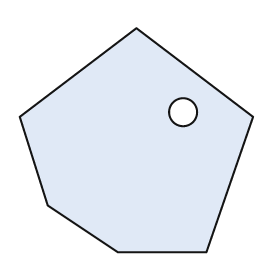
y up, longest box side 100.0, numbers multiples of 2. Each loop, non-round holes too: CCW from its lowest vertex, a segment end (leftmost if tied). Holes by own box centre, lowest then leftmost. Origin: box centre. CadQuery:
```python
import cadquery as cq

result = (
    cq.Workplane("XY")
    .moveTo(-8.0, -48.0)
    .lineTo(30.0, -48.0)
    .lineTo(50.0, 10.0)
    .lineTo(0.0, 48.0)
    .lineTo(-50.0, 10.0)
    .lineTo(-38.0, -28.0)
    .close()
    .moveTo(20.0, 12.0)
    .circle(6.0)
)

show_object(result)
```